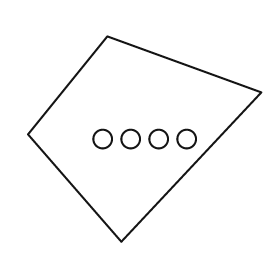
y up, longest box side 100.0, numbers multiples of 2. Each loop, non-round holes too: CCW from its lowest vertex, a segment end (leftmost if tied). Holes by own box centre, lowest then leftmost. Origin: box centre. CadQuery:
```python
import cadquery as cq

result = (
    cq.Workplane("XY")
    .moveTo(-10.0, -44.0)
    .lineTo(50.0, 20.0)
    .lineTo(-16.0, 44.0)
    .lineTo(-50.0, 2.0)
    .close()
    .moveTo(-18.0, 0.0)
    .circle(4.0)
    .moveTo(-6.0, 0.0)
    .circle(4.0)
    .moveTo(6.0, 0.0)
    .circle(4.0)
    .moveTo(18.0, 0.0)
    .circle(4.0)
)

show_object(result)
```